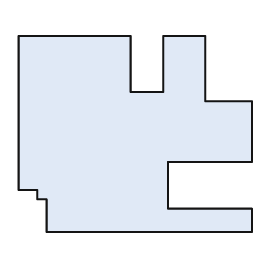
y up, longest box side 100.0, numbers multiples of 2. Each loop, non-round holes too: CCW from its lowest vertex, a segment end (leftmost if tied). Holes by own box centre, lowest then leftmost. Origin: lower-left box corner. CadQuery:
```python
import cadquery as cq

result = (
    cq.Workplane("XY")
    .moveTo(12.0, 0.0)
    .lineTo(100.0, 0.0)
    .lineTo(100.0, 10.0)
    .lineTo(64.0, 10.0)
    .lineTo(64.0, 30.0)
    .lineTo(100.0, 30.0)
    .lineTo(100.0, 56.0)
    .lineTo(80.0, 56.0)
    .lineTo(80.0, 84.0)
    .lineTo(62.0, 84.0)
    .lineTo(62.0, 60.0)
    .lineTo(48.0, 60.0)
    .lineTo(48.0, 84.0)
    .lineTo(0.0, 84.0)
    .lineTo(0.0, 18.0)
    .lineTo(8.0, 18.0)
    .lineTo(8.0, 14.0)
    .lineTo(12.0, 14.0)
    .close()
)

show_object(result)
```